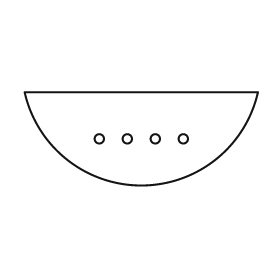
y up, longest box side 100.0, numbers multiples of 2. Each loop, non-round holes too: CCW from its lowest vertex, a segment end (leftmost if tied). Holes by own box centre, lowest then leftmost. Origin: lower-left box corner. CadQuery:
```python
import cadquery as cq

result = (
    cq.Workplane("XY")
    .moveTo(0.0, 40.0)
    .threePointArc((50.0, 0.0), (100.0, 40.0))
    .close()
    .moveTo(32.0, 20.0)
    .circle(2.0)
    .moveTo(44.0, 20.0)
    .circle(2.0)
    .moveTo(56.0, 20.0)
    .circle(2.0)
    .moveTo(68.0, 20.0)
    .circle(2.0)
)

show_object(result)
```